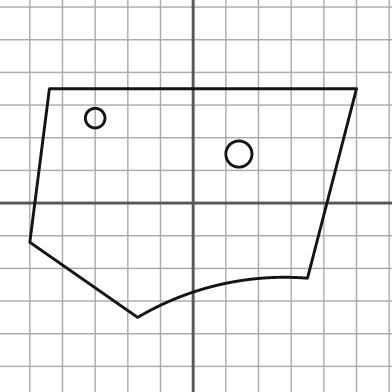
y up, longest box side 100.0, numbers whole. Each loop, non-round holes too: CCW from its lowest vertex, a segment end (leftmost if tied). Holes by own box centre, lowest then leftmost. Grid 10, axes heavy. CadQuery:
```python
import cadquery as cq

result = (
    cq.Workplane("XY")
    .moveTo(-17.0, -35.0)
    .threePointArc((8.0, -25.0), (35.0, -23.0))
    .lineTo(50.0, 35.0)
    .lineTo(-44.0, 35.0)
    .lineTo(-50.0, -12.0)
    .close()
    .moveTo(14.0, 15.0)
    .circle(4.0)
    .moveTo(-30.0, 26.0)
    .circle(3.0)
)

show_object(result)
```